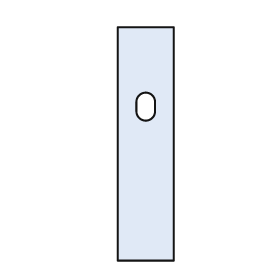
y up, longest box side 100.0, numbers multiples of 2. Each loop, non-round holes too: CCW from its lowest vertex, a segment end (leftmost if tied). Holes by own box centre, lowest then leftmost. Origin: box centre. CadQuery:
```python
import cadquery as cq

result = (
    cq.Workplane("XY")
    .moveTo(-12.0, -50.0)
    .lineTo(12.0, -50.0)
    .lineTo(12.0, 50.0)
    .lineTo(-12.0, 50.0)
    .close()
    .moveTo(-4.0, 14.0)
    .threePointArc((0.0, 10.0), (4.0, 14.0))
    .lineTo(4.0, 18.0)
    .threePointArc((0.0, 22.0), (-4.0, 18.0))
    .close()
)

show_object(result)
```